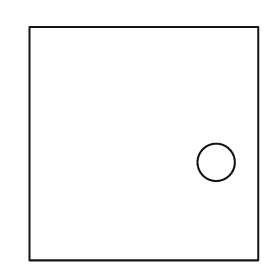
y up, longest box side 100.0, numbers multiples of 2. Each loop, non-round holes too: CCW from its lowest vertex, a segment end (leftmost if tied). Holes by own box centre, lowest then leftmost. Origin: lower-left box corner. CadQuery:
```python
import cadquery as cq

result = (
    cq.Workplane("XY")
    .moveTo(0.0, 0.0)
    .lineTo(98.0, 0.0)
    .lineTo(98.0, 100.0)
    .lineTo(0.0, 100.0)
    .close()
    .moveTo(80.0, 42.0)
    .circle(8.0)
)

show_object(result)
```